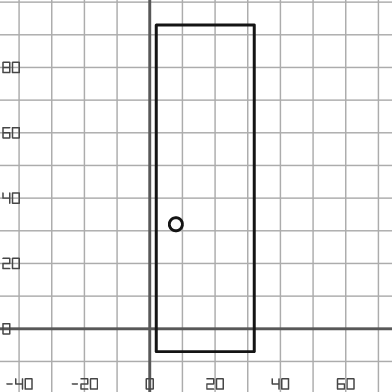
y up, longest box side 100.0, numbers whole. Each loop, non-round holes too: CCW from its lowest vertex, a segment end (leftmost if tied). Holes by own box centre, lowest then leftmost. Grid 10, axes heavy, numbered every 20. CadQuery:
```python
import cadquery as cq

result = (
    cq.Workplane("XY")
    .moveTo(2.0, -7.0)
    .lineTo(32.0, -7.0)
    .lineTo(32.0, 93.0)
    .lineTo(2.0, 93.0)
    .close()
    .moveTo(8.0, 32.0)
    .circle(2.0)
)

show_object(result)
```